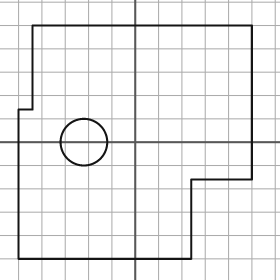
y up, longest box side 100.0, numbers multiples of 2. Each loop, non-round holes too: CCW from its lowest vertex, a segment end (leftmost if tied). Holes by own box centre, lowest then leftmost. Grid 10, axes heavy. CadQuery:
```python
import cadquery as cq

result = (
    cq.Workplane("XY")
    .moveTo(-50.0, -50.0)
    .lineTo(24.0, -50.0)
    .lineTo(24.0, -16.0)
    .lineTo(50.0, -16.0)
    .lineTo(50.0, 50.0)
    .lineTo(-44.0, 50.0)
    .lineTo(-44.0, 14.0)
    .lineTo(-50.0, 14.0)
    .close()
    .moveTo(-22.0, 0.0)
    .circle(10.0)
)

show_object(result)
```